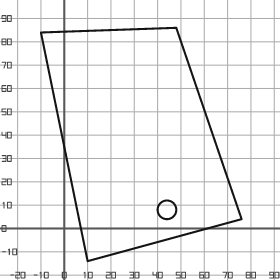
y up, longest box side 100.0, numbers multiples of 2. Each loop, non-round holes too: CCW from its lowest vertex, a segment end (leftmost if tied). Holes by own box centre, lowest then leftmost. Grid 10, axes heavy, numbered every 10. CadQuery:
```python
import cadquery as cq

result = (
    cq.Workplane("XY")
    .moveTo(10.0, -14.0)
    .lineTo(76.0, 4.0)
    .lineTo(48.0, 86.0)
    .lineTo(-10.0, 84.0)
    .close()
    .moveTo(44.0, 8.0)
    .circle(4.0)
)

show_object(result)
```